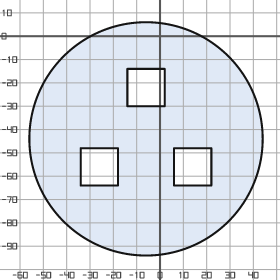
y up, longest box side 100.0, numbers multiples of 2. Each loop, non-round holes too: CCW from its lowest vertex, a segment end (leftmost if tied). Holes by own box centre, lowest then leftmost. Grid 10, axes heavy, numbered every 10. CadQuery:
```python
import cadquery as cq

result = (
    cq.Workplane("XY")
    .moveTo(-6.0, -44.0)
    .circle(50.0)
    .moveTo(-34.0, -64.0)
    .lineTo(-18.0, -64.0)
    .lineTo(-18.0, -48.0)
    .lineTo(-34.0, -48.0)
    .close()
    .moveTo(6.0, -64.0)
    .lineTo(22.0, -64.0)
    .lineTo(22.0, -48.0)
    .lineTo(6.0, -48.0)
    .close()
    .moveTo(-14.0, -30.0)
    .lineTo(2.0, -30.0)
    .lineTo(2.0, -14.0)
    .lineTo(-14.0, -14.0)
    .close()
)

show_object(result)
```